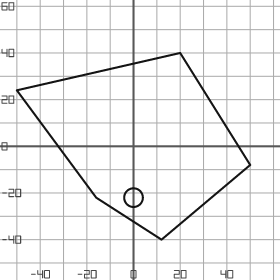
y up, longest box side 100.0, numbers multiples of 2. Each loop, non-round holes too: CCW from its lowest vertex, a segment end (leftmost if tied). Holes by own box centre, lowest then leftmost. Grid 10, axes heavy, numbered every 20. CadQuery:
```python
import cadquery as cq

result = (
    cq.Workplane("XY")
    .moveTo(12.0, -40.0)
    .lineTo(50.0, -8.0)
    .lineTo(20.0, 40.0)
    .lineTo(-50.0, 24.0)
    .lineTo(-16.0, -22.0)
    .close()
    .moveTo(0.0, -22.0)
    .circle(4.0)
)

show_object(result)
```